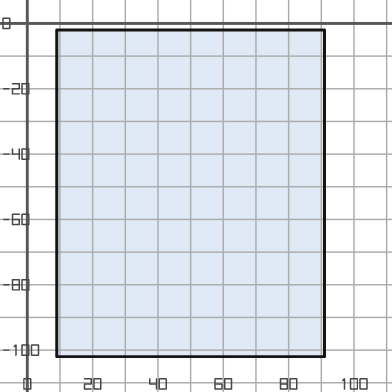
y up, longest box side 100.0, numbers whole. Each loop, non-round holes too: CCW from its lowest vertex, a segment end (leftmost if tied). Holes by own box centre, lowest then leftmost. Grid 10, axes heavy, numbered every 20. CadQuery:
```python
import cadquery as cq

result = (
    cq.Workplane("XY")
    .moveTo(9.0, -102.0)
    .lineTo(91.0, -102.0)
    .lineTo(91.0, -2.0)
    .lineTo(9.0, -2.0)
    .close()
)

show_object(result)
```